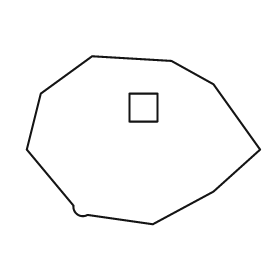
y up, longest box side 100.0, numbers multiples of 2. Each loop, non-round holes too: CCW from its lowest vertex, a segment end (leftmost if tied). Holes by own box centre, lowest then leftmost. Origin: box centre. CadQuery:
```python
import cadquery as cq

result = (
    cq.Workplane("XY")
    .moveTo(4.0, -36.0)
    .lineTo(30.0, -22.0)
    .lineTo(50.0, -4.0)
    .lineTo(30.0, 24.0)
    .lineTo(12.0, 34.0)
    .lineTo(-22.0, 36.0)
    .lineTo(-44.0, 20.0)
    .lineTo(-50.0, -4.0)
    .lineTo(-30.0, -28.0)
    .threePointArc((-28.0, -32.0), (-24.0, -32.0))
    .close()
    .moveTo(-6.0, 8.0)
    .lineTo(6.0, 8.0)
    .lineTo(6.0, 20.0)
    .lineTo(-6.0, 20.0)
    .close()
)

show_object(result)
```